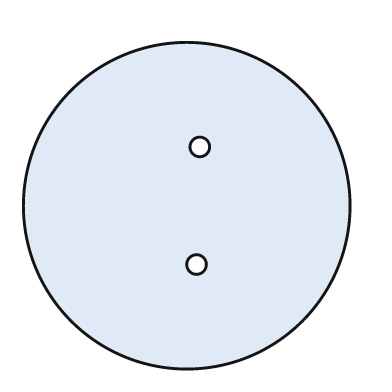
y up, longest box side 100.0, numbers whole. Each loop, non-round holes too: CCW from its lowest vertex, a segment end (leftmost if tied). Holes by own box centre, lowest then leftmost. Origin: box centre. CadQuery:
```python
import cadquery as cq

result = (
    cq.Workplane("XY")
    .moveTo(0.0, 0.0)
    .circle(50.0)
    .moveTo(3.0, -18.0)
    .circle(3.0)
    .moveTo(4.0, 18.0)
    .circle(3.0)
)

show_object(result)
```